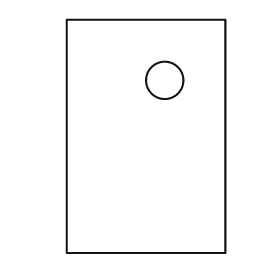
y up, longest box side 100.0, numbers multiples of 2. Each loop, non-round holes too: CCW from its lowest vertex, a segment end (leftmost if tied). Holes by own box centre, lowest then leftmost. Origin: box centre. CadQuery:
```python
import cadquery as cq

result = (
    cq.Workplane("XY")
    .moveTo(-34.0, -50.0)
    .lineTo(34.0, -50.0)
    .lineTo(34.0, 50.0)
    .lineTo(-34.0, 50.0)
    .close()
    .moveTo(8.0, 24.0)
    .circle(8.0)
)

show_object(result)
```